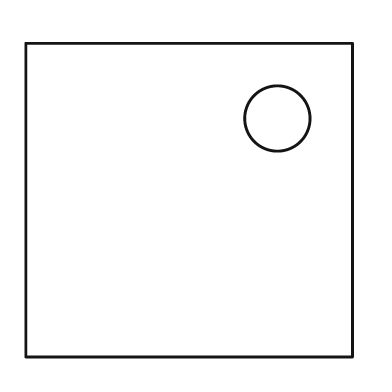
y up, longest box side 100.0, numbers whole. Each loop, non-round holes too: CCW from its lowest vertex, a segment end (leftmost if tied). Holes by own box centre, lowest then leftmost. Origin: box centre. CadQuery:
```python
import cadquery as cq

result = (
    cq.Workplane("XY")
    .moveTo(-50.0, -48.0)
    .lineTo(50.0, -48.0)
    .lineTo(50.0, 48.0)
    .lineTo(-50.0, 48.0)
    .close()
    .moveTo(27.0, 25.0)
    .circle(10.0)
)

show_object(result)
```